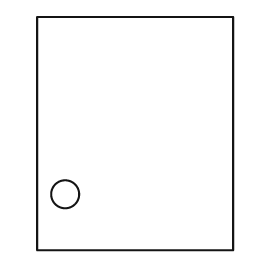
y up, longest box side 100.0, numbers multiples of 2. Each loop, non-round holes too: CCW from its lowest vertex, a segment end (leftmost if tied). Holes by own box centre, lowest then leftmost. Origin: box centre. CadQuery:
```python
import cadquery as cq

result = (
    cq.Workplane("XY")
    .moveTo(-42.0, -50.0)
    .lineTo(42.0, -50.0)
    .lineTo(42.0, 50.0)
    .lineTo(-42.0, 50.0)
    .close()
    .moveTo(-30.0, -26.0)
    .circle(6.0)
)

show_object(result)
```